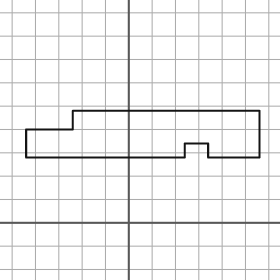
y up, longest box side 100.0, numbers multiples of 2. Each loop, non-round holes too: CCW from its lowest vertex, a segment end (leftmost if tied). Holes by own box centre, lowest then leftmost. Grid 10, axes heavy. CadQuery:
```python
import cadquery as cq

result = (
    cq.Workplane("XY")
    .moveTo(-44.0, 28.0)
    .lineTo(24.0, 28.0)
    .lineTo(24.0, 34.0)
    .lineTo(34.0, 34.0)
    .lineTo(34.0, 28.0)
    .lineTo(56.0, 28.0)
    .lineTo(56.0, 48.0)
    .lineTo(-24.0, 48.0)
    .lineTo(-24.0, 40.0)
    .lineTo(-44.0, 40.0)
    .close()
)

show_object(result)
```